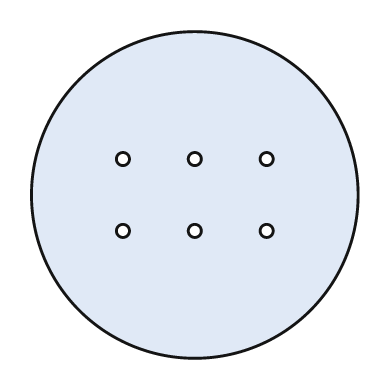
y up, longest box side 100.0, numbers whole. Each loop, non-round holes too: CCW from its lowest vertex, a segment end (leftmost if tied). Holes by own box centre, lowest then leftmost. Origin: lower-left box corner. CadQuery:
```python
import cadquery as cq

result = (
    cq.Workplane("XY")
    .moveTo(50.0, 50.0)
    .circle(50.0)
    .moveTo(28.0, 39.0)
    .circle(2.0)
    .moveTo(50.0, 39.0)
    .circle(2.0)
    .moveTo(72.0, 39.0)
    .circle(2.0)
    .moveTo(28.0, 61.0)
    .circle(2.0)
    .moveTo(50.0, 61.0)
    .circle(2.0)
    .moveTo(72.0, 61.0)
    .circle(2.0)
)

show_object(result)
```